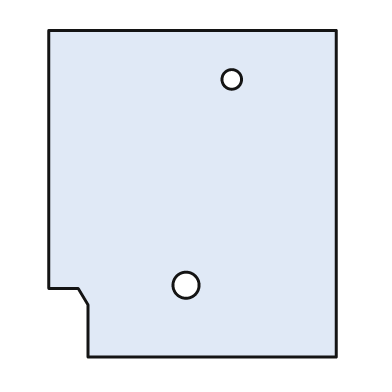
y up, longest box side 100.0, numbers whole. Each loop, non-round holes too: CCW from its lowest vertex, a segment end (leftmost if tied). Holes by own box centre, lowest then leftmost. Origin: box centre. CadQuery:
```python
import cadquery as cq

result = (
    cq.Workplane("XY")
    .moveTo(-32.0, -50.0)
    .lineTo(44.0, -50.0)
    .lineTo(44.0, 50.0)
    .lineTo(-44.0, 50.0)
    .lineTo(-44.0, -29.0)
    .lineTo(-35.0, -29.0)
    .lineTo(-32.0, -34.0)
    .close()
    .moveTo(-2.0, -28.0)
    .circle(4.0)
    .moveTo(12.0, 35.0)
    .circle(3.0)
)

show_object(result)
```